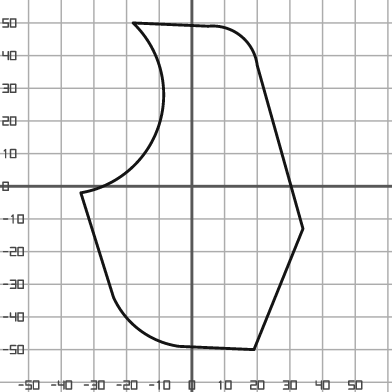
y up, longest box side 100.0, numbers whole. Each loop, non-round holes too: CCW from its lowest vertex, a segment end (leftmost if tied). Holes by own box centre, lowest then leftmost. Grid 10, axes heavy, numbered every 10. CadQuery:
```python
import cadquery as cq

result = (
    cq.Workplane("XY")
    .moveTo(19.0, -50.0)
    .lineTo(34.0, -13.0)
    .lineTo(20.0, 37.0)
    .threePointArc((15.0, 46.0), (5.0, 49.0))
    .lineTo(-18.0, 50.0)
    .threePointArc((-10.0, 19.0), (-34.0, -2.0))
    .lineTo(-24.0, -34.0)
    .threePointArc((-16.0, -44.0), (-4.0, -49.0))
    .close()
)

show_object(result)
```